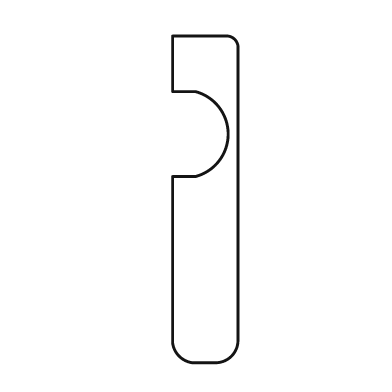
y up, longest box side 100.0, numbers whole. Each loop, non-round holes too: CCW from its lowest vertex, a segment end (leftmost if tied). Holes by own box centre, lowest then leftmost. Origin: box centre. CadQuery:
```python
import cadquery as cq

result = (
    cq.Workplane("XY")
    .moveTo(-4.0, -50.0)
    .lineTo(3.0, -50.0)
    .threePointArc((8.0, -48.0), (10.0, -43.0))
    .lineTo(10.0, 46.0)
    .threePointArc((9.0, 49.0), (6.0, 50.0))
    .lineTo(-10.0, 50.0)
    .lineTo(-10.0, 33.0)
    .lineTo(-3.0, 33.0)
    .threePointArc((7.0, 20.0), (-3.0, 7.0))
    .lineTo(-10.0, 7.0)
    .lineTo(-10.0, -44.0)
    .threePointArc((-8.0, -48.0), (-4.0, -50.0))
    .close()
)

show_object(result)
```